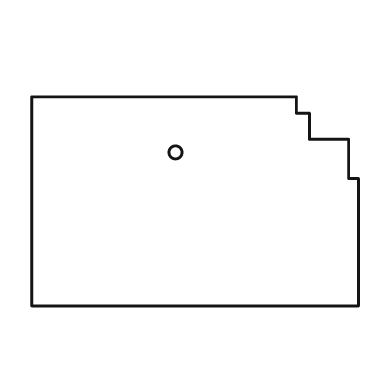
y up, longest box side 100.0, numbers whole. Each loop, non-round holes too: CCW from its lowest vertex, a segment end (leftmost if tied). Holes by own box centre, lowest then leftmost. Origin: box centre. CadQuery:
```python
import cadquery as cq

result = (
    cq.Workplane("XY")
    .moveTo(-50.0, -32.0)
    .lineTo(50.0, -32.0)
    .lineTo(50.0, 7.0)
    .lineTo(47.0, 7.0)
    .lineTo(47.0, 19.0)
    .lineTo(35.0, 19.0)
    .lineTo(35.0, 27.0)
    .lineTo(31.0, 27.0)
    .lineTo(31.0, 32.0)
    .lineTo(-50.0, 32.0)
    .close()
    .moveTo(-6.0, 15.0)
    .circle(2.0)
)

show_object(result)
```